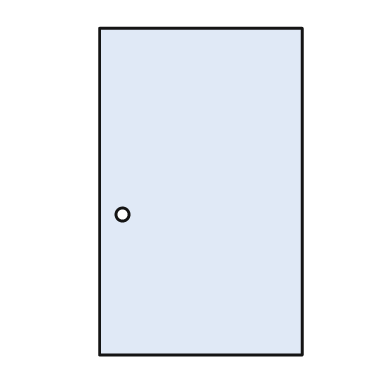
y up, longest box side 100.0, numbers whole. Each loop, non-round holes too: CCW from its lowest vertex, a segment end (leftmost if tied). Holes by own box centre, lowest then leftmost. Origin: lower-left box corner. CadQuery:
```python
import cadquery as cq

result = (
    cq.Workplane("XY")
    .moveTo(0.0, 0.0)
    .lineTo(62.0, 0.0)
    .lineTo(62.0, 100.0)
    .lineTo(0.0, 100.0)
    .close()
    .moveTo(7.0, 43.0)
    .circle(2.0)
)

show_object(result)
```